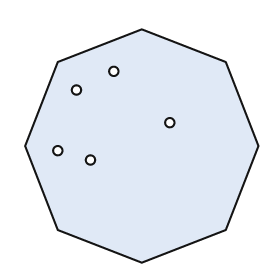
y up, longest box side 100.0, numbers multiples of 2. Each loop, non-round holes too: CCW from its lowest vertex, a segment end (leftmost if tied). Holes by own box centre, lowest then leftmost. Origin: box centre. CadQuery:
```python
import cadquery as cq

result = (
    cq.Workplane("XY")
    .moveTo(0.0, -50.0)
    .lineTo(36.0, -36.0)
    .lineTo(50.0, 0.0)
    .lineTo(36.0, 36.0)
    .lineTo(0.0, 50.0)
    .lineTo(-36.0, 36.0)
    .lineTo(-50.0, 0.0)
    .lineTo(-36.0, -36.0)
    .close()
    .moveTo(-22.0, -6.0)
    .circle(2.0)
    .moveTo(-36.0, -2.0)
    .circle(2.0)
    .moveTo(12.0, 10.0)
    .circle(2.0)
    .moveTo(-28.0, 24.0)
    .circle(2.0)
    .moveTo(-12.0, 32.0)
    .circle(2.0)
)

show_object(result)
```